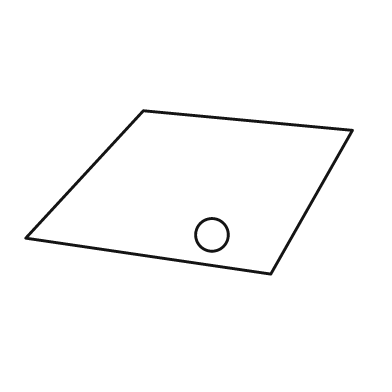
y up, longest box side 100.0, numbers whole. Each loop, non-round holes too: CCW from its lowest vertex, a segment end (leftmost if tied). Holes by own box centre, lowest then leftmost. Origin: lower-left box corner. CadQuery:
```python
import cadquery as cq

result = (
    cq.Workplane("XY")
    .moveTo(75.0, 0.0)
    .lineTo(100.0, 44.0)
    .lineTo(36.0, 50.0)
    .lineTo(0.0, 11.0)
    .close()
    .moveTo(57.0, 12.0)
    .circle(5.0)
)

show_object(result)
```